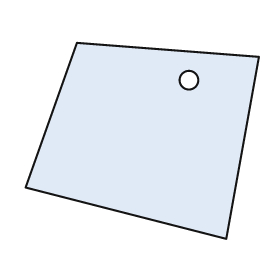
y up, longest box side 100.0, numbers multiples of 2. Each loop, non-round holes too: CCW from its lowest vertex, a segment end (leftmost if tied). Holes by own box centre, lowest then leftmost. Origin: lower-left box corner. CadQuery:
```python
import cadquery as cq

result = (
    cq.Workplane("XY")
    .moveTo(86.0, 0.0)
    .lineTo(100.0, 78.0)
    .lineTo(22.0, 84.0)
    .lineTo(0.0, 22.0)
    .close()
    .moveTo(70.0, 68.0)
    .circle(4.0)
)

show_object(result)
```